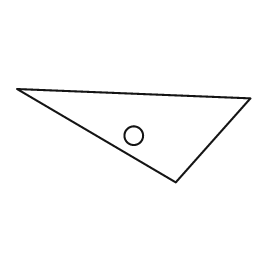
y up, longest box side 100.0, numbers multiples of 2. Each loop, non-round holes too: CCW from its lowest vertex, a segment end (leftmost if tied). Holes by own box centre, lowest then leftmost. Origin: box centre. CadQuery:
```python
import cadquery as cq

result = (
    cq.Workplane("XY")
    .moveTo(18.0, -20.0)
    .lineTo(50.0, 16.0)
    .lineTo(-50.0, 20.0)
    .close()
    .moveTo(0.0, 0.0)
    .circle(4.0)
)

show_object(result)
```